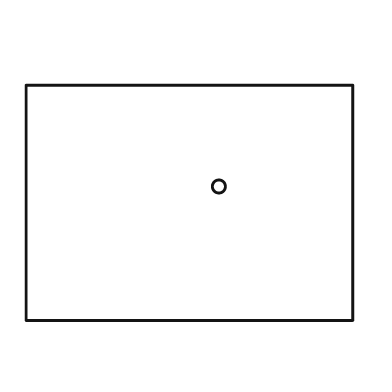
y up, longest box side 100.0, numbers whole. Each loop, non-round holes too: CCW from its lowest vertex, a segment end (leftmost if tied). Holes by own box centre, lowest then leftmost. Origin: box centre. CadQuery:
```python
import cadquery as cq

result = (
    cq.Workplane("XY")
    .moveTo(-50.0, -36.0)
    .lineTo(50.0, -36.0)
    .lineTo(50.0, 36.0)
    .lineTo(-50.0, 36.0)
    .close()
    .moveTo(9.0, 5.0)
    .circle(2.0)
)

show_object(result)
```